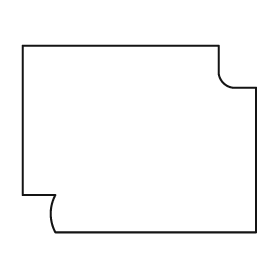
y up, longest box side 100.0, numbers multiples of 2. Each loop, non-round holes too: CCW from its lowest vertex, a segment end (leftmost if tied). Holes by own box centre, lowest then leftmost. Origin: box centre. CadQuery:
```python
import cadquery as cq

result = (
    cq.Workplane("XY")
    .moveTo(-36.0, -40.0)
    .lineTo(50.0, -40.0)
    .lineTo(50.0, 22.0)
    .lineTo(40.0, 22.0)
    .threePointArc((36.0, 24.0), (34.0, 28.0))
    .lineTo(34.0, 40.0)
    .lineTo(-50.0, 40.0)
    .lineTo(-50.0, -24.0)
    .lineTo(-36.0, -24.0)
    .threePointArc((-38.0, -32.0), (-36.0, -40.0))
    .close()
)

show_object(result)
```